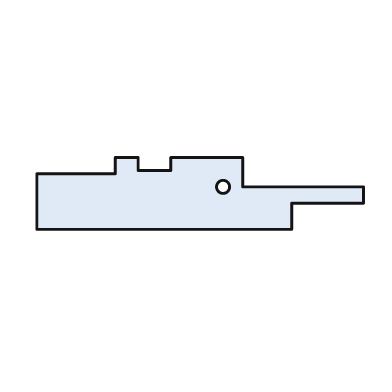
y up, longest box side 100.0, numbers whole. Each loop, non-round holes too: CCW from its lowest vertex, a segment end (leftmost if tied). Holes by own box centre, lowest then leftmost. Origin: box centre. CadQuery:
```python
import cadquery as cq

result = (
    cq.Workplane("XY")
    .moveTo(-50.0, -11.0)
    .lineTo(28.0, -11.0)
    .lineTo(28.0, -3.0)
    .lineTo(50.0, -3.0)
    .lineTo(50.0, 2.0)
    .lineTo(13.0, 2.0)
    .lineTo(13.0, 11.0)
    .lineTo(-9.0, 11.0)
    .lineTo(-9.0, 7.0)
    .lineTo(-19.0, 7.0)
    .lineTo(-19.0, 11.0)
    .lineTo(-26.0, 11.0)
    .lineTo(-26.0, 6.0)
    .lineTo(-50.0, 6.0)
    .close()
    .moveTo(7.0, 2.0)
    .circle(2.0)
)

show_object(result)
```